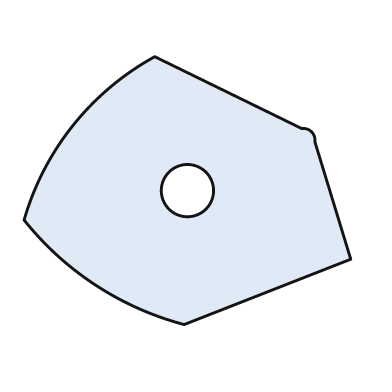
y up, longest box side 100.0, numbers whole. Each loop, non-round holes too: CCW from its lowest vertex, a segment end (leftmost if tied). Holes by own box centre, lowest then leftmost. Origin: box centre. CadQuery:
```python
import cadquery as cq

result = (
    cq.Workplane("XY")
    .moveTo(-1.0, -41.0)
    .lineTo(50.0, -21.0)
    .lineTo(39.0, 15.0)
    .threePointArc((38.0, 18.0), (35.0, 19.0))
    .lineTo(-10.0, 41.0)
    .threePointArc((-35.0, 20.0), (-50.0, -9.0))
    .threePointArc((-28.0, -29.0), (-1.0, -41.0))
    .close()
    .moveTo(0.0, 0.0)
    .circle(8.0)
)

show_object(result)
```